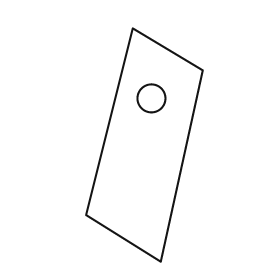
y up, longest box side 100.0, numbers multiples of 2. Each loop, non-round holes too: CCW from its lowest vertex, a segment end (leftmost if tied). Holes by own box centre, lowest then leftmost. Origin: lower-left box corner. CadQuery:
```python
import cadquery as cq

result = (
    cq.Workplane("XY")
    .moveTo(32.0, 0.0)
    .lineTo(50.0, 82.0)
    .lineTo(20.0, 100.0)
    .lineTo(0.0, 20.0)
    .close()
    .moveTo(28.0, 70.0)
    .circle(6.0)
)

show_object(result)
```